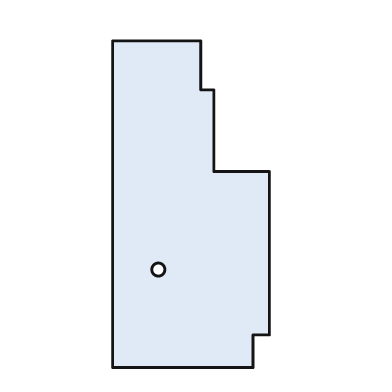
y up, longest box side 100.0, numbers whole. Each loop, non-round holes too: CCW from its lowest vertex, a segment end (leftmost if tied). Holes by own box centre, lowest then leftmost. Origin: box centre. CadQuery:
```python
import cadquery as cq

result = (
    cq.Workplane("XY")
    .moveTo(-24.0, -50.0)
    .lineTo(19.0, -50.0)
    .lineTo(19.0, -40.0)
    .lineTo(24.0, -40.0)
    .lineTo(24.0, 10.0)
    .lineTo(7.0, 10.0)
    .lineTo(7.0, 35.0)
    .lineTo(3.0, 35.0)
    .lineTo(3.0, 50.0)
    .lineTo(-24.0, 50.0)
    .close()
    .moveTo(-10.0, -20.0)
    .circle(2.0)
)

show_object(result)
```